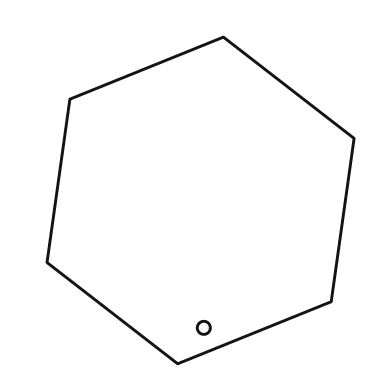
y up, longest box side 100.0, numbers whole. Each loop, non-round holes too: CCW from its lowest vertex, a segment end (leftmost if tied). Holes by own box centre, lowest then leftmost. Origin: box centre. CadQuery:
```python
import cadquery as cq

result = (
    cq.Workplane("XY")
    .moveTo(-7.0, -50.0)
    .lineTo(40.0, -31.0)
    .lineTo(47.0, 19.0)
    .lineTo(7.0, 50.0)
    .lineTo(-40.0, 31.0)
    .lineTo(-47.0, -19.0)
    .close()
    .moveTo(1.0, -39.0)
    .circle(2.0)
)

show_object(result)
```